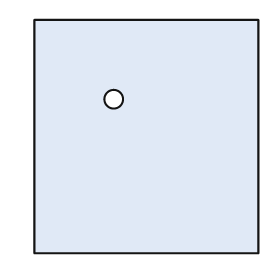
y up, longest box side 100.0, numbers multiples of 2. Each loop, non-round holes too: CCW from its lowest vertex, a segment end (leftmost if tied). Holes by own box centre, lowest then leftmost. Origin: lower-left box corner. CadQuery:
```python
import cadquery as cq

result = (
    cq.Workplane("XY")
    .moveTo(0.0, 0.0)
    .lineTo(96.0, 0.0)
    .lineTo(96.0, 100.0)
    .lineTo(0.0, 100.0)
    .close()
    .moveTo(34.0, 66.0)
    .circle(4.0)
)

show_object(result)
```